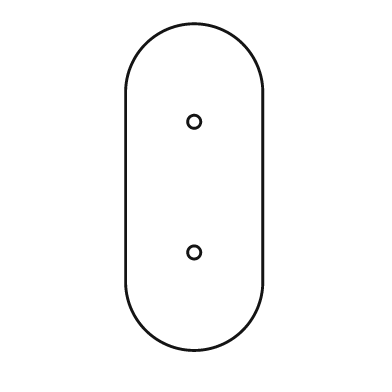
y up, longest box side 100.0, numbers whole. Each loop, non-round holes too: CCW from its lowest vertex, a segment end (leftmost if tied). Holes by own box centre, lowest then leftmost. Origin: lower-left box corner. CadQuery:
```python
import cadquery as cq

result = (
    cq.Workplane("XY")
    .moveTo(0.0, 21.0)
    .threePointArc((21.0, 0.0), (42.0, 21.0))
    .lineTo(42.0, 79.0)
    .threePointArc((21.0, 100.0), (0.0, 79.0))
    .close()
    .moveTo(21.0, 30.0)
    .circle(2.0)
    .moveTo(21.0, 70.0)
    .circle(2.0)
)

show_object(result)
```